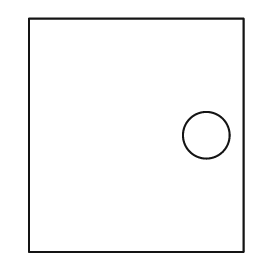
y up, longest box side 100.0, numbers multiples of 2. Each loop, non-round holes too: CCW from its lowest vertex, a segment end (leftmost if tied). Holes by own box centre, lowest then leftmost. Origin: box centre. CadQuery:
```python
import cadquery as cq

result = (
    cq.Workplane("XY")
    .moveTo(-46.0, -50.0)
    .lineTo(46.0, -50.0)
    .lineTo(46.0, 50.0)
    .lineTo(-46.0, 50.0)
    .close()
    .moveTo(30.0, 0.0)
    .circle(10.0)
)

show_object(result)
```